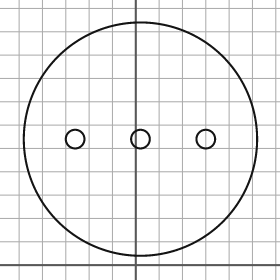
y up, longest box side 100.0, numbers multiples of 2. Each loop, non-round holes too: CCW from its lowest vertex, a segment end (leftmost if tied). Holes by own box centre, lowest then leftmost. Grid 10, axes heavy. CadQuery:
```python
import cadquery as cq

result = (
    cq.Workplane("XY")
    .moveTo(2.0, 54.0)
    .circle(50.0)
    .moveTo(-26.0, 54.0)
    .circle(4.0)
    .moveTo(2.0, 54.0)
    .circle(4.0)
    .moveTo(30.0, 54.0)
    .circle(4.0)
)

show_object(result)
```